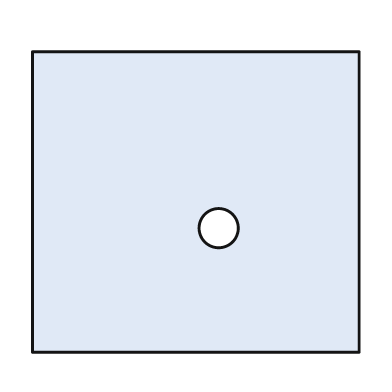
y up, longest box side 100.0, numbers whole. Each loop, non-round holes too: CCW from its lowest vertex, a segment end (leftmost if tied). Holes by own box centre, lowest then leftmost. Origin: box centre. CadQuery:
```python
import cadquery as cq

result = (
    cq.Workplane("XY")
    .moveTo(-50.0, -46.0)
    .lineTo(50.0, -46.0)
    .lineTo(50.0, 46.0)
    .lineTo(-50.0, 46.0)
    .close()
    .moveTo(7.0, -8.0)
    .circle(6.0)
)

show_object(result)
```